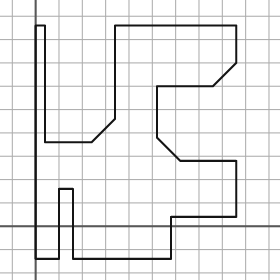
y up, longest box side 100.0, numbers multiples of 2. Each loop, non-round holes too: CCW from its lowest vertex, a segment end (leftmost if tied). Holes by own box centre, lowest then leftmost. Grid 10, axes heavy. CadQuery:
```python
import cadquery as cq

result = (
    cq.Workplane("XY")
    .moveTo(0.0, -14.0)
    .lineTo(10.0, -14.0)
    .lineTo(10.0, 16.0)
    .lineTo(16.0, 16.0)
    .lineTo(16.0, -14.0)
    .lineTo(58.0, -14.0)
    .lineTo(58.0, 4.0)
    .lineTo(86.0, 4.0)
    .lineTo(86.0, 28.0)
    .lineTo(62.0, 28.0)
    .lineTo(52.0, 38.0)
    .lineTo(52.0, 60.0)
    .lineTo(76.0, 60.0)
    .lineTo(86.0, 70.0)
    .lineTo(86.0, 86.0)
    .lineTo(34.0, 86.0)
    .lineTo(34.0, 46.0)
    .lineTo(24.0, 36.0)
    .lineTo(4.0, 36.0)
    .lineTo(4.0, 86.0)
    .lineTo(0.0, 86.0)
    .close()
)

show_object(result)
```